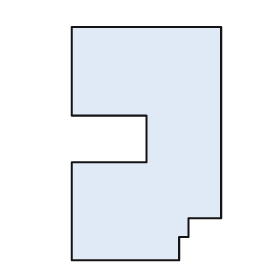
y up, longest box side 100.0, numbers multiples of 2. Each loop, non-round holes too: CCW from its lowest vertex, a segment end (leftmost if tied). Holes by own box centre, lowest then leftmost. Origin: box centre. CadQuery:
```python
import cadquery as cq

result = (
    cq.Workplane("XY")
    .moveTo(-32.0, -50.0)
    .lineTo(14.0, -50.0)
    .lineTo(14.0, -40.0)
    .lineTo(18.0, -40.0)
    .lineTo(18.0, -32.0)
    .lineTo(32.0, -32.0)
    .lineTo(32.0, 50.0)
    .lineTo(-32.0, 50.0)
    .lineTo(-32.0, 12.0)
    .lineTo(0.0, 12.0)
    .lineTo(0.0, -8.0)
    .lineTo(-32.0, -8.0)
    .close()
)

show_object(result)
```